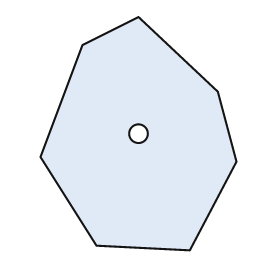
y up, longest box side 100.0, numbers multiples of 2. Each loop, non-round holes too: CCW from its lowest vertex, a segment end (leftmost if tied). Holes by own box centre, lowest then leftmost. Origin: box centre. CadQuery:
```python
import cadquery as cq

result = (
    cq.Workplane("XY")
    .moveTo(22.0, -50.0)
    .lineTo(42.0, -12.0)
    .lineTo(34.0, 18.0)
    .lineTo(0.0, 50.0)
    .lineTo(-24.0, 38.0)
    .lineTo(-42.0, -10.0)
    .lineTo(-18.0, -48.0)
    .close()
    .moveTo(0.0, 0.0)
    .circle(4.0)
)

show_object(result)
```